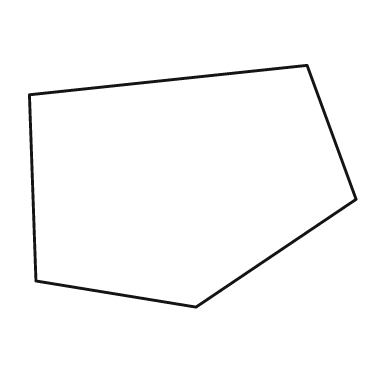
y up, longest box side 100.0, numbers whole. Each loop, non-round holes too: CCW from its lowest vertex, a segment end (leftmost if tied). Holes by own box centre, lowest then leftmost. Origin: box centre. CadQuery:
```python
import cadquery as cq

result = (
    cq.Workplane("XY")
    .moveTo(1.0, -37.0)
    .lineTo(50.0, -4.0)
    .lineTo(35.0, 37.0)
    .lineTo(-50.0, 28.0)
    .lineTo(-48.0, -29.0)
    .close()
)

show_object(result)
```